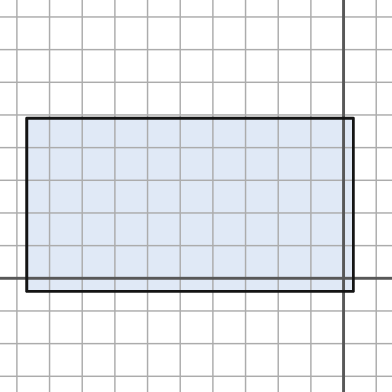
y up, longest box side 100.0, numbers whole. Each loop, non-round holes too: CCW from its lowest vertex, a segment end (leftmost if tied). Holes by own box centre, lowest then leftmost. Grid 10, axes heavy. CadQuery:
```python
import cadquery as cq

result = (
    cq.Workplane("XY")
    .moveTo(-97.0, -4.0)
    .lineTo(3.0, -4.0)
    .lineTo(3.0, 49.0)
    .lineTo(-97.0, 49.0)
    .close()
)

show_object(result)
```